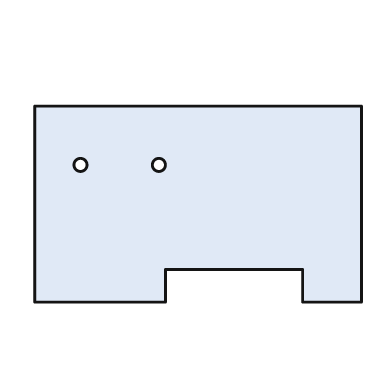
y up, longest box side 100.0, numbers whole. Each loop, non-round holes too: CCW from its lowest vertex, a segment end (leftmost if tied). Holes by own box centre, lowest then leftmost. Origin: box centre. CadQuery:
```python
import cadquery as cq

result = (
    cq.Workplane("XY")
    .moveTo(-50.0, -30.0)
    .lineTo(-10.0, -30.0)
    .lineTo(-10.0, -20.0)
    .lineTo(32.0, -20.0)
    .lineTo(32.0, -30.0)
    .lineTo(50.0, -30.0)
    .lineTo(50.0, 30.0)
    .lineTo(-50.0, 30.0)
    .close()
    .moveTo(-36.0, 12.0)
    .circle(2.0)
    .moveTo(-12.0, 12.0)
    .circle(2.0)
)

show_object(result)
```